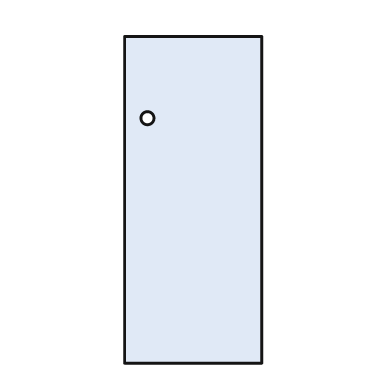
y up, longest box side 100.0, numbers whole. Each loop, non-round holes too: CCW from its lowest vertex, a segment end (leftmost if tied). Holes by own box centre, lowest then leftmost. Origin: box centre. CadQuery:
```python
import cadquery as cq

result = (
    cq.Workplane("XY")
    .moveTo(-21.0, -50.0)
    .lineTo(21.0, -50.0)
    .lineTo(21.0, 50.0)
    .lineTo(-21.0, 50.0)
    .close()
    .moveTo(-14.0, 25.0)
    .circle(2.0)
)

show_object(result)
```